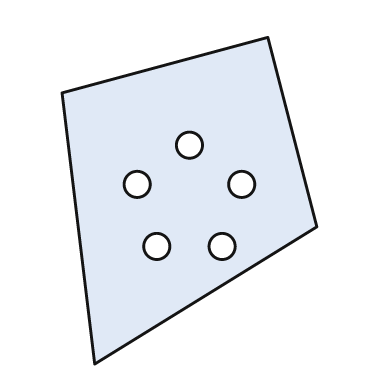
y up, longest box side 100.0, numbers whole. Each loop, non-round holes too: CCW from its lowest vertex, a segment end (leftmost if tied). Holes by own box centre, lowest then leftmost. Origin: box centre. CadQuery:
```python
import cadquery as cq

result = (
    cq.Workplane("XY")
    .moveTo(-29.0, -50.0)
    .lineTo(39.0, -8.0)
    .lineTo(24.0, 50.0)
    .lineTo(-39.0, 33.0)
    .close()
    .moveTo(-10.0, -14.0)
    .circle(4.0)
    .moveTo(10.0, -14.0)
    .circle(4.0)
    .moveTo(-16.0, 5.0)
    .circle(4.0)
    .moveTo(16.0, 5.0)
    .circle(4.0)
    .moveTo(0.0, 17.0)
    .circle(4.0)
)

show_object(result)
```